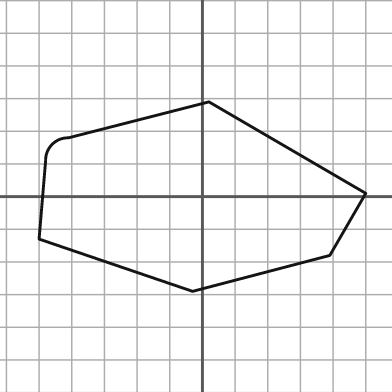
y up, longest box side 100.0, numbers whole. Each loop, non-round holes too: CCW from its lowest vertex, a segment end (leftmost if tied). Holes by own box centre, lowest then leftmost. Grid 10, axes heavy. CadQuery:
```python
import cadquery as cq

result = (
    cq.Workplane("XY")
    .moveTo(-3.0, -29.0)
    .lineTo(39.0, -18.0)
    .lineTo(50.0, 1.0)
    .lineTo(2.0, 29.0)
    .lineTo(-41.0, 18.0)
    .threePointArc((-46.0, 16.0), (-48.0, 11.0))
    .lineTo(-50.0, -13.0)
    .close()
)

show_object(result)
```